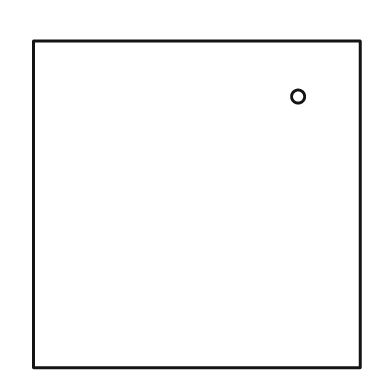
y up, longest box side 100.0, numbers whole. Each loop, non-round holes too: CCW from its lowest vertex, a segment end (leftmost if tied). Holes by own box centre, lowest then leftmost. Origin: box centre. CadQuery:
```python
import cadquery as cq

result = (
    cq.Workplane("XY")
    .moveTo(-50.0, -50.0)
    .lineTo(50.0, -50.0)
    .lineTo(50.0, 50.0)
    .lineTo(-50.0, 50.0)
    .close()
    .moveTo(31.0, 33.0)
    .circle(2.0)
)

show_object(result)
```